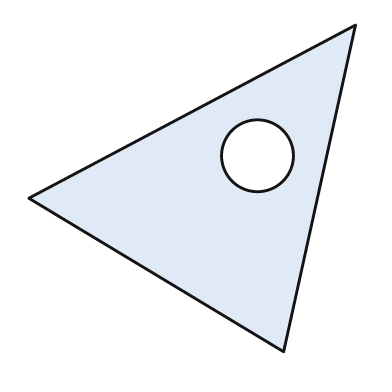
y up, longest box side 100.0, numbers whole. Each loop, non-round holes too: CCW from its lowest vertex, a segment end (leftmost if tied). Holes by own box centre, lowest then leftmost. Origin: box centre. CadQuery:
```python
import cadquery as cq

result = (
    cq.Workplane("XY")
    .moveTo(28.0, -50.0)
    .lineTo(50.0, 50.0)
    .lineTo(-50.0, -3.0)
    .close()
    .moveTo(20.0, 10.0)
    .circle(11.0)
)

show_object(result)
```